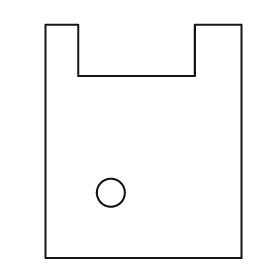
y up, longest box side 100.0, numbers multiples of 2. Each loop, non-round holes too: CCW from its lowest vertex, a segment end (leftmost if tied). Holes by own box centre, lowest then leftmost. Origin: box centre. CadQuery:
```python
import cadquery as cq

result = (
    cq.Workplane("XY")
    .moveTo(-42.0, -50.0)
    .lineTo(42.0, -50.0)
    .lineTo(42.0, 50.0)
    .lineTo(22.0, 50.0)
    .lineTo(22.0, 28.0)
    .lineTo(-28.0, 28.0)
    .lineTo(-28.0, 50.0)
    .lineTo(-42.0, 50.0)
    .close()
    .moveTo(-14.0, -22.0)
    .circle(6.0)
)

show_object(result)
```